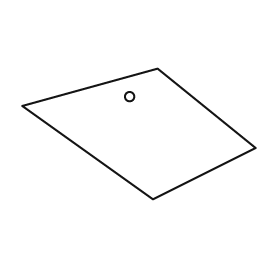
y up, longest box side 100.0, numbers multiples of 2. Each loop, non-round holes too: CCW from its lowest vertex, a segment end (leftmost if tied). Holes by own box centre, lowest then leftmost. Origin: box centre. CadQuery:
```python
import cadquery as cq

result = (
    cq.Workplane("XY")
    .moveTo(6.0, -28.0)
    .lineTo(50.0, -6.0)
    .lineTo(8.0, 28.0)
    .lineTo(-50.0, 12.0)
    .close()
    .moveTo(-4.0, 16.0)
    .circle(2.0)
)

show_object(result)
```